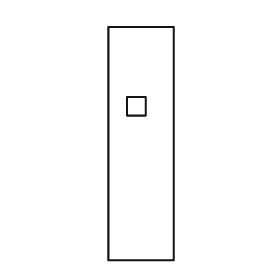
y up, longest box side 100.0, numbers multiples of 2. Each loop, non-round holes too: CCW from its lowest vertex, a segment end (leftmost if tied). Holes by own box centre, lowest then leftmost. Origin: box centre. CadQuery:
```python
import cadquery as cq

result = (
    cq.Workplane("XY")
    .moveTo(-14.0, -50.0)
    .lineTo(14.0, -50.0)
    .lineTo(14.0, 50.0)
    .lineTo(-14.0, 50.0)
    .close()
    .moveTo(-6.0, 12.0)
    .lineTo(2.0, 12.0)
    .lineTo(2.0, 20.0)
    .lineTo(-6.0, 20.0)
    .close()
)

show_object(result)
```